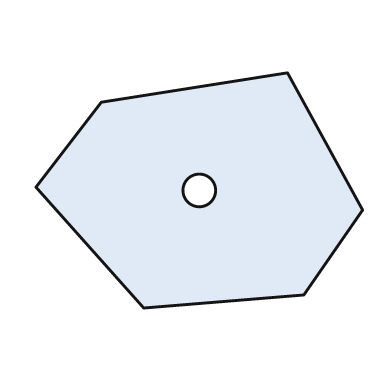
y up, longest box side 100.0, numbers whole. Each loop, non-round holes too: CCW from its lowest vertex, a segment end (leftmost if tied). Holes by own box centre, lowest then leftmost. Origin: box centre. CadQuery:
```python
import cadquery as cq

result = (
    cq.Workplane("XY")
    .moveTo(-17.0, -36.0)
    .lineTo(32.0, -32.0)
    .lineTo(50.0, -6.0)
    .lineTo(27.0, 36.0)
    .lineTo(-30.0, 27.0)
    .lineTo(-50.0, 1.0)
    .close()
    .moveTo(0.0, 0.0)
    .circle(5.0)
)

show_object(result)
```